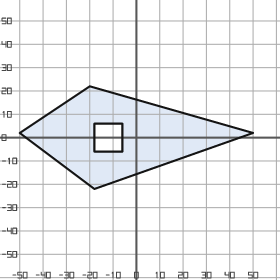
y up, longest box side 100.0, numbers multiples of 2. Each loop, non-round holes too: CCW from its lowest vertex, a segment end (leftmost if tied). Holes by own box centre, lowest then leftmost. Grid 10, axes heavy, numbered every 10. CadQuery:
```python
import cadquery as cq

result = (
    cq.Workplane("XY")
    .moveTo(-18.0, -22.0)
    .lineTo(50.0, 2.0)
    .lineTo(-20.0, 22.0)
    .lineTo(-50.0, 2.0)
    .close()
    .moveTo(-18.0, -6.0)
    .lineTo(-6.0, -6.0)
    .lineTo(-6.0, 6.0)
    .lineTo(-18.0, 6.0)
    .close()
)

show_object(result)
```